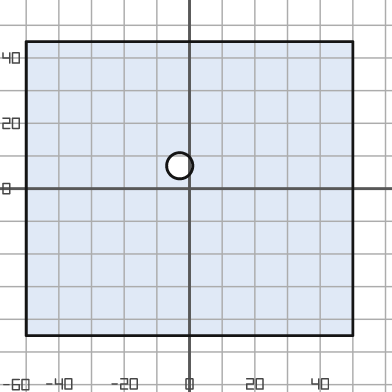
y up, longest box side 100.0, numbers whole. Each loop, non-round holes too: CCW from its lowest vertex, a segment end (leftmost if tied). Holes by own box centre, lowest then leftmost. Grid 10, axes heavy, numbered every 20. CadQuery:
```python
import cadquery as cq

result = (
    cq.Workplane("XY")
    .moveTo(-50.0, -45.0)
    .lineTo(50.0, -45.0)
    .lineTo(50.0, 45.0)
    .lineTo(-50.0, 45.0)
    .close()
    .moveTo(-3.0, 7.0)
    .circle(4.0)
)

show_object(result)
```